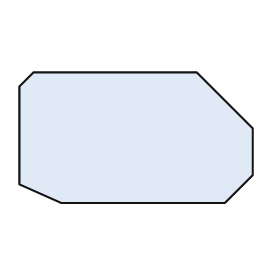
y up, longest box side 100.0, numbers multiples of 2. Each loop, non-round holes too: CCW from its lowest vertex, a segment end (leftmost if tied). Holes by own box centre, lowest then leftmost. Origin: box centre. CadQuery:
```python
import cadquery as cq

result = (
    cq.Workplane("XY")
    .moveTo(-32.0, -28.0)
    .lineTo(38.0, -28.0)
    .lineTo(50.0, -16.0)
    .lineTo(50.0, 4.0)
    .lineTo(26.0, 28.0)
    .lineTo(-44.0, 28.0)
    .lineTo(-50.0, 22.0)
    .lineTo(-50.0, -20.0)
    .close()
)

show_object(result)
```